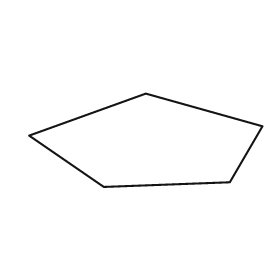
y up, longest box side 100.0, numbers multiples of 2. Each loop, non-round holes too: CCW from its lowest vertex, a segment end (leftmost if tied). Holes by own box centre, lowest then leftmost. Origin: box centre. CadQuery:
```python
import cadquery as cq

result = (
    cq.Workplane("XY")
    .moveTo(-18.0, -20.0)
    .lineTo(36.0, -18.0)
    .lineTo(50.0, 6.0)
    .lineTo(0.0, 20.0)
    .lineTo(-50.0, 2.0)
    .close()
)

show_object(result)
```